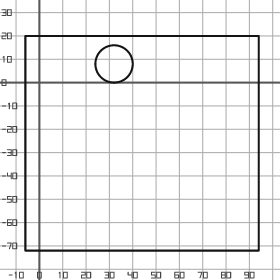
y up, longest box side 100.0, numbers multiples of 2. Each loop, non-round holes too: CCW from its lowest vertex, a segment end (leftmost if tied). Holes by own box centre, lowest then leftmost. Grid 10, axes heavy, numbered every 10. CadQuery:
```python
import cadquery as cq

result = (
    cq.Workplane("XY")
    .moveTo(-6.0, -72.0)
    .lineTo(94.0, -72.0)
    .lineTo(94.0, 20.0)
    .lineTo(-6.0, 20.0)
    .close()
    .moveTo(32.0, 8.0)
    .circle(8.0)
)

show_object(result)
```